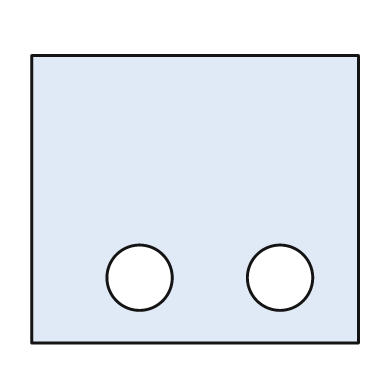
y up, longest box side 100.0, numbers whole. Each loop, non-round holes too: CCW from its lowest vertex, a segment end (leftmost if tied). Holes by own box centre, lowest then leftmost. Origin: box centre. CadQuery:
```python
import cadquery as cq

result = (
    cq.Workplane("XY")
    .moveTo(-50.0, -44.0)
    .lineTo(50.0, -44.0)
    .lineTo(50.0, 44.0)
    .lineTo(-50.0, 44.0)
    .close()
    .moveTo(-17.0, -24.0)
    .circle(10.0)
    .moveTo(26.0, -24.0)
    .circle(10.0)
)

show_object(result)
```